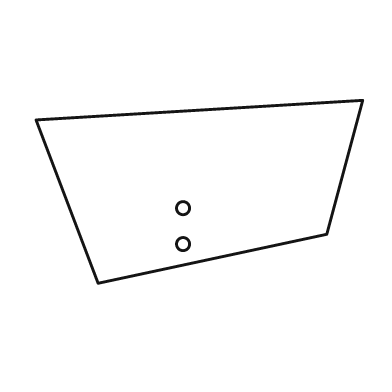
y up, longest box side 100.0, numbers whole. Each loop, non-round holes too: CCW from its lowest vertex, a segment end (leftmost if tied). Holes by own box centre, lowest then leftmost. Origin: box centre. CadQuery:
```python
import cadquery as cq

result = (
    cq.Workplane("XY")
    .moveTo(-31.0, -28.0)
    .lineTo(39.0, -13.0)
    .lineTo(50.0, 28.0)
    .lineTo(-50.0, 22.0)
    .close()
    .moveTo(-5.0, -16.0)
    .circle(2.0)
    .moveTo(-5.0, -5.0)
    .circle(2.0)
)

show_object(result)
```